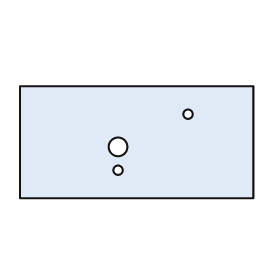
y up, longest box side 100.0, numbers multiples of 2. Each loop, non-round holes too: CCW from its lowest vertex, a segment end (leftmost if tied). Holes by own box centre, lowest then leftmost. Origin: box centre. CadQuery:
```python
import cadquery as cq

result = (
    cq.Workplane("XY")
    .moveTo(-50.0, -24.0)
    .lineTo(50.0, -24.0)
    .lineTo(50.0, 24.0)
    .lineTo(-50.0, 24.0)
    .close()
    .moveTo(-8.0, -12.0)
    .circle(2.0)
    .moveTo(-8.0, -2.0)
    .circle(4.0)
    .moveTo(22.0, 12.0)
    .circle(2.0)
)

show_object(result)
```